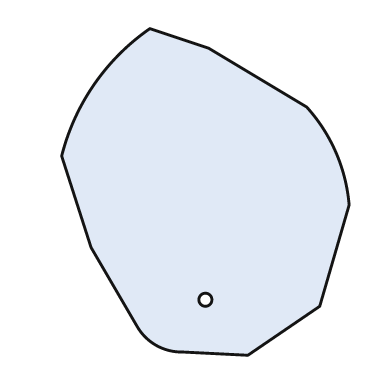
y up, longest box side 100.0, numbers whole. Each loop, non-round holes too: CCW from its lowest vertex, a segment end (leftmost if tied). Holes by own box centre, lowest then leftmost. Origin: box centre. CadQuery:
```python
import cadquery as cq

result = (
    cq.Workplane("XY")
    .moveTo(13.0, -50.0)
    .lineTo(35.0, -35.0)
    .lineTo(44.0, -4.0)
    .threePointArc((40.0, 12.0), (31.0, 26.0))
    .lineTo(1.0, 44.0)
    .lineTo(-17.0, 50.0)
    .threePointArc((-34.0, 33.0), (-44.0, 11.0))
    .lineTo(-35.0, -17.0)
    .lineTo(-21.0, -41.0)
    .threePointArc((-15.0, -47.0), (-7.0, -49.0))
    .close()
    .moveTo(0.0, -33.0)
    .circle(2.0)
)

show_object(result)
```